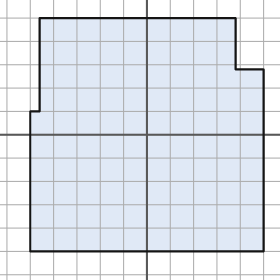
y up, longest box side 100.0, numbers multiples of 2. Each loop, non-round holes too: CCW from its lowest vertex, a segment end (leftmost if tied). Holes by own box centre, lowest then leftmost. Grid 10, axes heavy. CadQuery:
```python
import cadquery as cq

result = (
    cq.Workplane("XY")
    .moveTo(-50.0, -50.0)
    .lineTo(50.0, -50.0)
    .lineTo(50.0, 28.0)
    .lineTo(38.0, 28.0)
    .lineTo(38.0, 50.0)
    .lineTo(-46.0, 50.0)
    .lineTo(-46.0, 10.0)
    .lineTo(-50.0, 10.0)
    .close()
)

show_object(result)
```